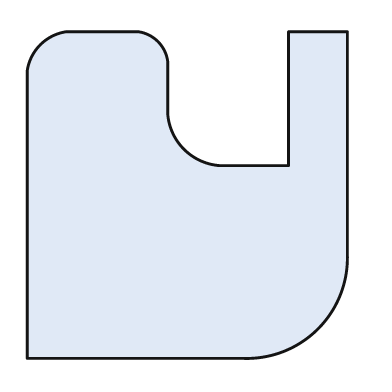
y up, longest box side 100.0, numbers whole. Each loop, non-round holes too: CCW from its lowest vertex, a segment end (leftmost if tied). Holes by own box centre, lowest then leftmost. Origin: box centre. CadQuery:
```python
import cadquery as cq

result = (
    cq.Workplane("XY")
    .moveTo(-49.0, -50.0)
    .lineTo(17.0, -50.0)
    .threePointArc((40.0, -41.0), (49.0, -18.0))
    .lineTo(49.0, 50.0)
    .lineTo(31.0, 50.0)
    .lineTo(31.0, 9.0)
    .lineTo(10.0, 9.0)
    .threePointArc((-1.0, 14.0), (-6.0, 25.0))
    .lineTo(-6.0, 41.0)
    .threePointArc((-9.0, 47.0), (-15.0, 50.0))
    .lineTo(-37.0, 50.0)
    .threePointArc((-45.0, 46.0), (-49.0, 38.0))
    .close()
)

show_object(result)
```